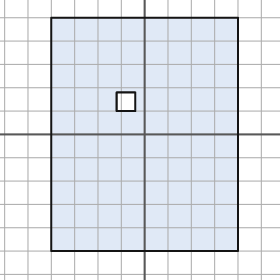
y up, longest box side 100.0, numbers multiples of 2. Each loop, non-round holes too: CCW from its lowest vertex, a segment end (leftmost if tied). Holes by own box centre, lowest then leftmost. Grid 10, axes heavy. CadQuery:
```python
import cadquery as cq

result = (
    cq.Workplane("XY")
    .moveTo(-40.0, -50.0)
    .lineTo(40.0, -50.0)
    .lineTo(40.0, 50.0)
    .lineTo(-40.0, 50.0)
    .close()
    .moveTo(-12.0, 10.0)
    .lineTo(-4.0, 10.0)
    .lineTo(-4.0, 18.0)
    .lineTo(-12.0, 18.0)
    .close()
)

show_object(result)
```